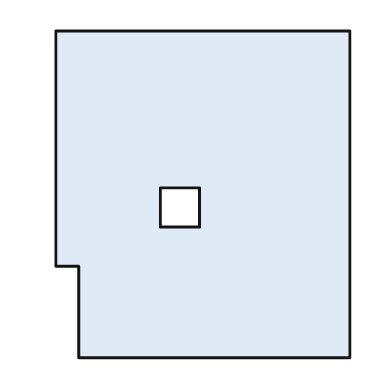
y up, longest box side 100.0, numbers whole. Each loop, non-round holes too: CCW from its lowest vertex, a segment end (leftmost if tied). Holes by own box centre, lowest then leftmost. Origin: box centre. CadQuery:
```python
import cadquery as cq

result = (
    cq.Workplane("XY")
    .moveTo(-38.0, -50.0)
    .lineTo(45.0, -50.0)
    .lineTo(45.0, 50.0)
    .lineTo(-45.0, 50.0)
    .lineTo(-45.0, -22.0)
    .lineTo(-38.0, -22.0)
    .close()
    .moveTo(-13.0, -10.0)
    .lineTo(-1.0, -10.0)
    .lineTo(-1.0, 2.0)
    .lineTo(-13.0, 2.0)
    .close()
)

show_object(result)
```